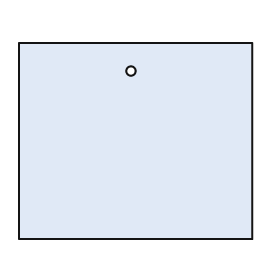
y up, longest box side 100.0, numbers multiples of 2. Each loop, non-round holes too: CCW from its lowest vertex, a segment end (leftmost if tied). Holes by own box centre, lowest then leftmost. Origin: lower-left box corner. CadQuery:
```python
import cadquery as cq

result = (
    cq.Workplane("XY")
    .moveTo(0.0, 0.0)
    .lineTo(100.0, 0.0)
    .lineTo(100.0, 84.0)
    .lineTo(0.0, 84.0)
    .close()
    .moveTo(48.0, 72.0)
    .circle(2.0)
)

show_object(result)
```